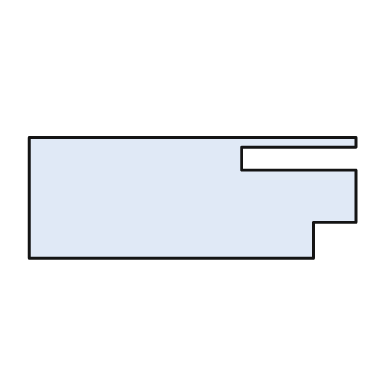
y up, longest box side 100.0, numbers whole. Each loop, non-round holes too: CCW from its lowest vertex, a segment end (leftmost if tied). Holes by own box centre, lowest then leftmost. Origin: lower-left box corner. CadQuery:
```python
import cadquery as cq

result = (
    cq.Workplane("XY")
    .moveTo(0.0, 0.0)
    .lineTo(87.0, 0.0)
    .lineTo(87.0, 11.0)
    .lineTo(100.0, 11.0)
    .lineTo(100.0, 27.0)
    .lineTo(65.0, 27.0)
    .lineTo(65.0, 34.0)
    .lineTo(100.0, 34.0)
    .lineTo(100.0, 37.0)
    .lineTo(0.0, 37.0)
    .close()
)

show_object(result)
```